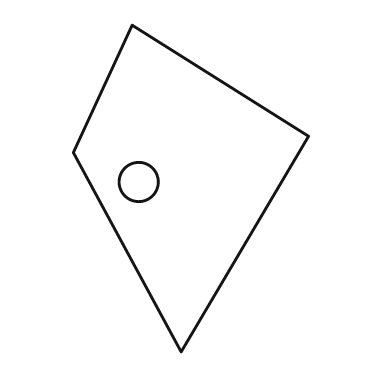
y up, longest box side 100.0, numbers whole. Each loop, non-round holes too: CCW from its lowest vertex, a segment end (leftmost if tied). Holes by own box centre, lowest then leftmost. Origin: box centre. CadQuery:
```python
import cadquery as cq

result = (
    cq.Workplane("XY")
    .moveTo(-3.0, -50.0)
    .lineTo(36.0, 16.0)
    .lineTo(-18.0, 50.0)
    .lineTo(-36.0, 11.0)
    .close()
    .moveTo(-16.0, 2.0)
    .circle(6.0)
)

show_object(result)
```